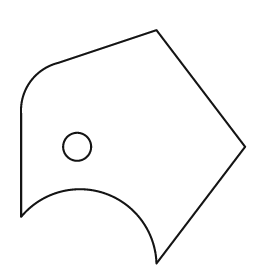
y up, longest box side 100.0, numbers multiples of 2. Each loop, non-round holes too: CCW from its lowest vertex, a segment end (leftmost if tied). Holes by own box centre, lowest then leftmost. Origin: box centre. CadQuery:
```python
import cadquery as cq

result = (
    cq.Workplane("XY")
    .moveTo(10.0, -50.0)
    .lineTo(48.0, 0.0)
    .lineTo(10.0, 50.0)
    .lineTo(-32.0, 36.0)
    .threePointArc((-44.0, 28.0), (-48.0, 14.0))
    .lineTo(-48.0, -30.0)
    .threePointArc((-12.0, -20.0), (10.0, -50.0))
    .close()
    .moveTo(-24.0, 0.0)
    .circle(6.0)
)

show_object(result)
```